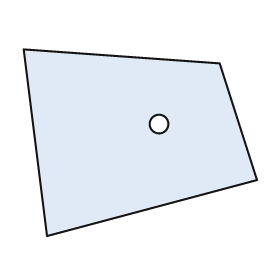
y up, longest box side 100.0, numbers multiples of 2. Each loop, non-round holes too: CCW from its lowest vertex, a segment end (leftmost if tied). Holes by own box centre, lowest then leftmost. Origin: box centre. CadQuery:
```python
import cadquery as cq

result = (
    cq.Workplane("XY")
    .moveTo(-40.0, -40.0)
    .lineTo(50.0, -16.0)
    .lineTo(34.0, 34.0)
    .lineTo(-50.0, 40.0)
    .close()
    .moveTo(8.0, 8.0)
    .circle(4.0)
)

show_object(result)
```